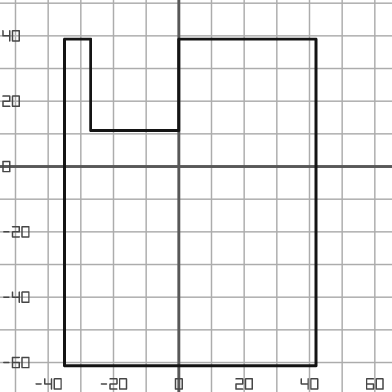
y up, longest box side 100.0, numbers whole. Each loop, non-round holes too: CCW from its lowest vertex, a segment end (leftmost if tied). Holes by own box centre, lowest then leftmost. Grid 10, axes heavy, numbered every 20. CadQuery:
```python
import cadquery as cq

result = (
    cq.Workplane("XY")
    .moveTo(-35.0, -61.0)
    .lineTo(42.0, -61.0)
    .lineTo(42.0, 39.0)
    .lineTo(0.0, 39.0)
    .lineTo(0.0, 11.0)
    .lineTo(-27.0, 11.0)
    .lineTo(-27.0, 39.0)
    .lineTo(-35.0, 39.0)
    .close()
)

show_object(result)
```